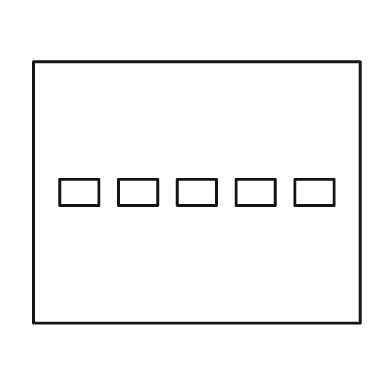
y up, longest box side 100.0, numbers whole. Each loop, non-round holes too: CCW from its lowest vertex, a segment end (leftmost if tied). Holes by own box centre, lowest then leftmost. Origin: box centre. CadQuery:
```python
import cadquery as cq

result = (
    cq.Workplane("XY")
    .moveTo(-50.0, -40.0)
    .lineTo(50.0, -40.0)
    .lineTo(50.0, 40.0)
    .lineTo(-50.0, 40.0)
    .close()
    .moveTo(-42.0, -4.0)
    .lineTo(-30.0, -4.0)
    .lineTo(-30.0, 4.0)
    .lineTo(-42.0, 4.0)
    .close()
    .moveTo(-24.0, -4.0)
    .lineTo(-12.0, -4.0)
    .lineTo(-12.0, 4.0)
    .lineTo(-24.0, 4.0)
    .close()
    .moveTo(-6.0, -4.0)
    .lineTo(6.0, -4.0)
    .lineTo(6.0, 4.0)
    .lineTo(-6.0, 4.0)
    .close()
    .moveTo(12.0, -4.0)
    .lineTo(24.0, -4.0)
    .lineTo(24.0, 4.0)
    .lineTo(12.0, 4.0)
    .close()
    .moveTo(30.0, -4.0)
    .lineTo(42.0, -4.0)
    .lineTo(42.0, 4.0)
    .lineTo(30.0, 4.0)
    .close()
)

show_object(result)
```